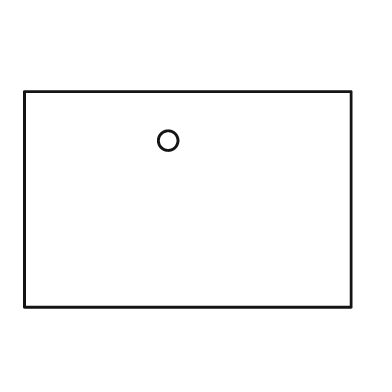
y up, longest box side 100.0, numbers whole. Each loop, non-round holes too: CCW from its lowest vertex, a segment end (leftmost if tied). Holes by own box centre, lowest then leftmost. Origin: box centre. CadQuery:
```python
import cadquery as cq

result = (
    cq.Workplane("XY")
    .moveTo(-50.0, -33.0)
    .lineTo(50.0, -33.0)
    .lineTo(50.0, 33.0)
    .lineTo(-50.0, 33.0)
    .close()
    .moveTo(-6.0, 18.0)
    .circle(3.0)
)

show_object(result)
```